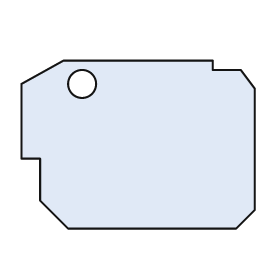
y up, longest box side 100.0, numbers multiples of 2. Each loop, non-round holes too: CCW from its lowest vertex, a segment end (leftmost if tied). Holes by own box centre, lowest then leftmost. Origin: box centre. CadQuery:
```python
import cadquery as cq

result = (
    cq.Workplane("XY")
    .moveTo(-30.0, -36.0)
    .lineTo(42.0, -36.0)
    .lineTo(50.0, -28.0)
    .lineTo(50.0, 24.0)
    .lineTo(44.0, 32.0)
    .lineTo(32.0, 32.0)
    .lineTo(32.0, 36.0)
    .lineTo(-32.0, 36.0)
    .lineTo(-50.0, 26.0)
    .lineTo(-50.0, -6.0)
    .lineTo(-42.0, -6.0)
    .lineTo(-42.0, -24.0)
    .close()
    .moveTo(-24.0, 26.0)
    .circle(6.0)
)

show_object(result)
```